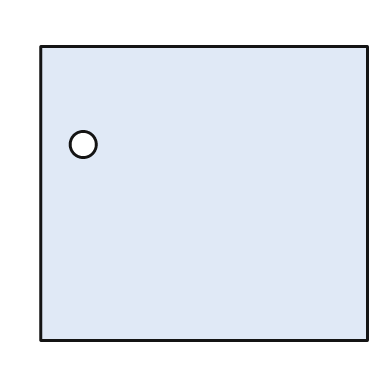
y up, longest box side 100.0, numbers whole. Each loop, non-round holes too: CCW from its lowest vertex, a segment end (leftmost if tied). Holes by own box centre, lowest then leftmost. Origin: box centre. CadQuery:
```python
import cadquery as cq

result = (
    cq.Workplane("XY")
    .moveTo(-50.0, -45.0)
    .lineTo(50.0, -45.0)
    .lineTo(50.0, 45.0)
    .lineTo(-50.0, 45.0)
    .close()
    .moveTo(-37.0, 15.0)
    .circle(4.0)
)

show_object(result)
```